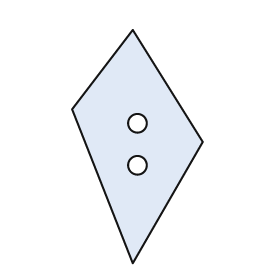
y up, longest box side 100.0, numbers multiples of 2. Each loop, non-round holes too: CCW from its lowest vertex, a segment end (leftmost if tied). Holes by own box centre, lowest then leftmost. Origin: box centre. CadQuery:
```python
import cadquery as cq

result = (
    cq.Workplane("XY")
    .moveTo(-2.0, -50.0)
    .lineTo(28.0, 2.0)
    .lineTo(-2.0, 50.0)
    .lineTo(-28.0, 16.0)
    .close()
    .moveTo(0.0, -8.0)
    .circle(4.0)
    .moveTo(0.0, 10.0)
    .circle(4.0)
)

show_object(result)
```